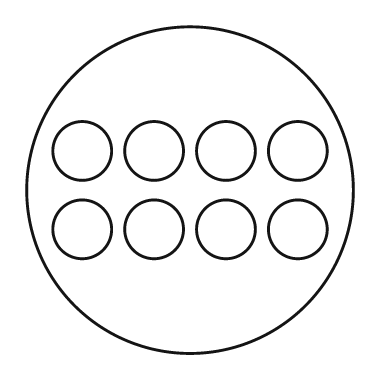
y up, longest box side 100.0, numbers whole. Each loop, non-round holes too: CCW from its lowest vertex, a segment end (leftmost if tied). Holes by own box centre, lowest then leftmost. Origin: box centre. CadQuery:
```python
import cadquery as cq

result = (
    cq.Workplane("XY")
    .moveTo(0.0, 0.0)
    .circle(50.0)
    .moveTo(-33.0, -12.0)
    .circle(9.0)
    .moveTo(-11.0, -12.0)
    .circle(9.0)
    .moveTo(11.0, -12.0)
    .circle(9.0)
    .moveTo(33.0, -12.0)
    .circle(9.0)
    .moveTo(-33.0, 12.0)
    .circle(9.0)
    .moveTo(-11.0, 12.0)
    .circle(9.0)
    .moveTo(11.0, 12.0)
    .circle(9.0)
    .moveTo(33.0, 12.0)
    .circle(9.0)
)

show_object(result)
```